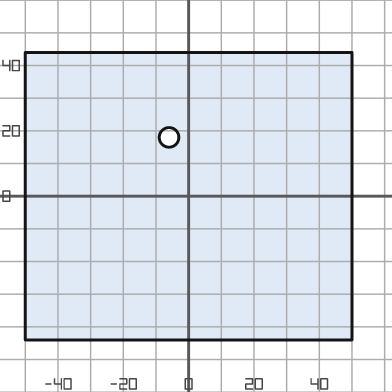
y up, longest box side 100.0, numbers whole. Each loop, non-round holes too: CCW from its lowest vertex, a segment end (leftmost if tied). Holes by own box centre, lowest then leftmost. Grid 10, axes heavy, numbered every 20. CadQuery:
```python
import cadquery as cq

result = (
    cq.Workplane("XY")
    .moveTo(-50.0, -44.0)
    .lineTo(50.0, -44.0)
    .lineTo(50.0, 44.0)
    .lineTo(-50.0, 44.0)
    .close()
    .moveTo(-6.0, 18.0)
    .circle(3.0)
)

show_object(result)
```